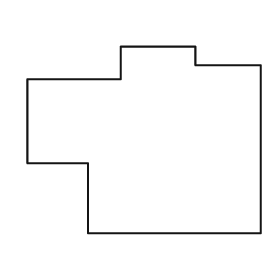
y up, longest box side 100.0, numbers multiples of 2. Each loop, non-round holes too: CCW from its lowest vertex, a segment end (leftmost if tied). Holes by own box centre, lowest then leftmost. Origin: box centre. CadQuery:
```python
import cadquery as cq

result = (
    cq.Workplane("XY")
    .moveTo(-24.0, -40.0)
    .lineTo(50.0, -40.0)
    .lineTo(50.0, 32.0)
    .lineTo(22.0, 32.0)
    .lineTo(22.0, 40.0)
    .lineTo(-10.0, 40.0)
    .lineTo(-10.0, 26.0)
    .lineTo(-50.0, 26.0)
    .lineTo(-50.0, -10.0)
    .lineTo(-24.0, -10.0)
    .close()
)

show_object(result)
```